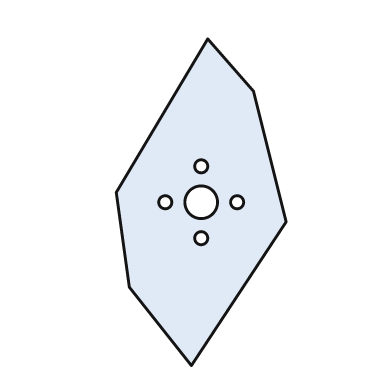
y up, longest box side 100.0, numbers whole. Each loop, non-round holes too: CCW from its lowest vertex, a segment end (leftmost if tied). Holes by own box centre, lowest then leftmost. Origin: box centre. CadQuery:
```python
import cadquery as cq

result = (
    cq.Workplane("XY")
    .moveTo(-3.0, -50.0)
    .lineTo(26.0, -6.0)
    .lineTo(16.0, 34.0)
    .lineTo(2.0, 50.0)
    .lineTo(-26.0, 3.0)
    .lineTo(-22.0, -26.0)
    .close()
    .moveTo(0.0, -11.0)
    .circle(2.0)
    .moveTo(-11.0, 0.0)
    .circle(2.0)
    .moveTo(0.0, 0.0)
    .circle(5.0)
    .moveTo(11.0, 0.0)
    .circle(2.0)
    .moveTo(0.0, 11.0)
    .circle(2.0)
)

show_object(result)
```